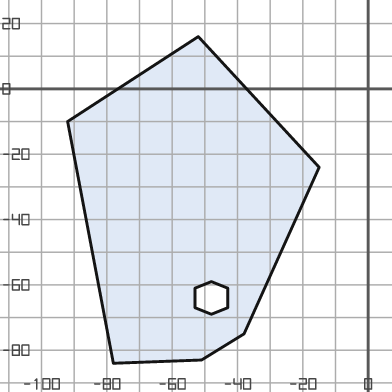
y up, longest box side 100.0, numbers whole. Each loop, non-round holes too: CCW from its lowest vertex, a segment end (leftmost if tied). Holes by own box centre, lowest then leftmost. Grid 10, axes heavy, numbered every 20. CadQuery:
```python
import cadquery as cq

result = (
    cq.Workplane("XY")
    .moveTo(-78.0, -84.0)
    .lineTo(-51.0, -83.0)
    .lineTo(-38.0, -75.0)
    .lineTo(-15.0, -24.0)
    .lineTo(-52.0, 16.0)
    .lineTo(-92.0, -10.0)
    .close()
    .moveTo(-48.0, -69.0)
    .lineTo(-43.0, -67.0)
    .lineTo(-43.0, -61.0)
    .lineTo(-48.0, -59.0)
    .lineTo(-53.0, -61.0)
    .lineTo(-53.0, -67.0)
    .close()
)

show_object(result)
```